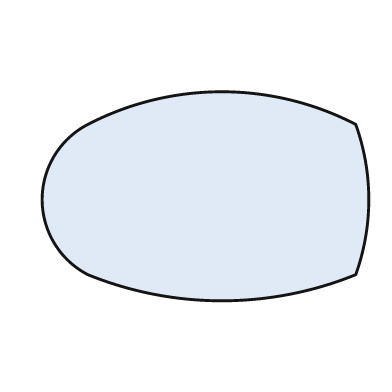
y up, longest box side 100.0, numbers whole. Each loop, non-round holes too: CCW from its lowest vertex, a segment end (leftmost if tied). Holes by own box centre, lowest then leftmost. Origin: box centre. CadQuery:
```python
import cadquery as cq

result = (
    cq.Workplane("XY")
    .moveTo(-36.0, -24.0)
    .threePointArc((5.0, -32.0), (46.0, -24.0))
    .threePointArc((50.0, -1.0), (46.0, 22.0))
    .threePointArc((5.0, 32.0), (-36.0, 22.0))
    .threePointArc((-50.0, -1.0), (-36.0, -24.0))
    .close()
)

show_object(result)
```